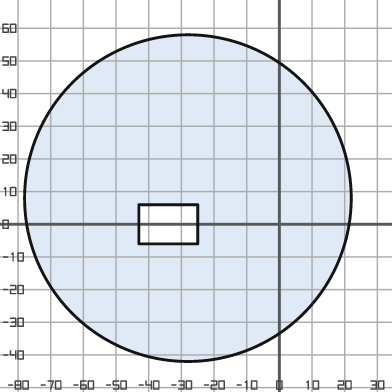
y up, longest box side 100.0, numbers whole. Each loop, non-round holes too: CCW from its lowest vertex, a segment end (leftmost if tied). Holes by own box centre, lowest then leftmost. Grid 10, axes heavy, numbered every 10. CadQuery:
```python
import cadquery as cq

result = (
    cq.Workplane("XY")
    .moveTo(-28.0, 8.0)
    .circle(50.0)
    .moveTo(-43.0, -6.0)
    .lineTo(-25.0, -6.0)
    .lineTo(-25.0, 6.0)
    .lineTo(-43.0, 6.0)
    .close()
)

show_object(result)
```